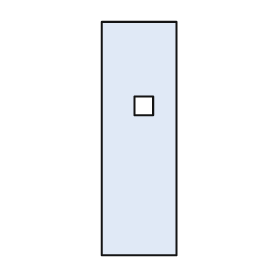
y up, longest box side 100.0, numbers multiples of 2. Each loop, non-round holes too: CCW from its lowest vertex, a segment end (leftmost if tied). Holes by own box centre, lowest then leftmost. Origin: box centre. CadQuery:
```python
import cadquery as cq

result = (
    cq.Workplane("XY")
    .moveTo(-16.0, -50.0)
    .lineTo(16.0, -50.0)
    .lineTo(16.0, 50.0)
    .lineTo(-16.0, 50.0)
    .close()
    .moveTo(-2.0, 10.0)
    .lineTo(6.0, 10.0)
    .lineTo(6.0, 18.0)
    .lineTo(-2.0, 18.0)
    .close()
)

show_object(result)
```